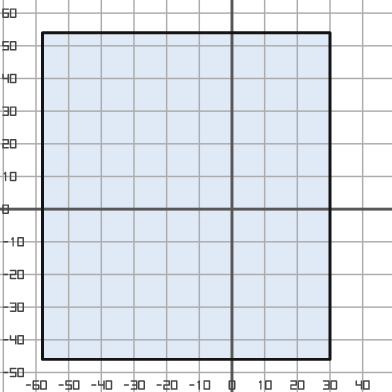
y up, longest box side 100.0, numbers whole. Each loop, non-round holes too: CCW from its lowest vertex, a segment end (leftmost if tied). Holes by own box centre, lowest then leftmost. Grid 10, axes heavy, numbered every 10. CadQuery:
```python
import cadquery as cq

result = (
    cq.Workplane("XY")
    .moveTo(-58.0, -46.0)
    .lineTo(30.0, -46.0)
    .lineTo(30.0, 54.0)
    .lineTo(-58.0, 54.0)
    .close()
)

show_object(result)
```